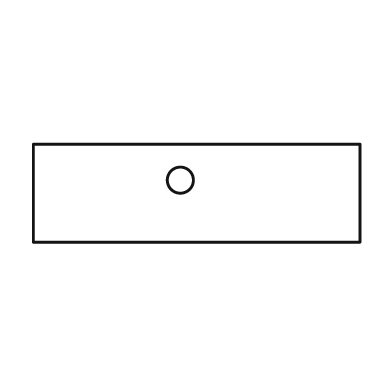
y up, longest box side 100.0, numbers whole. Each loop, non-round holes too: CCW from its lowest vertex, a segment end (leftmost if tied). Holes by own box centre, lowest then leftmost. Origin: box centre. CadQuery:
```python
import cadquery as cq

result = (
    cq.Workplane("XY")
    .moveTo(-50.0, -15.0)
    .lineTo(50.0, -15.0)
    .lineTo(50.0, 15.0)
    .lineTo(-50.0, 15.0)
    .close()
    .moveTo(-5.0, 4.0)
    .circle(4.0)
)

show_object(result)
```